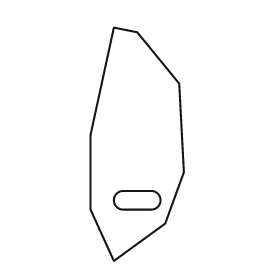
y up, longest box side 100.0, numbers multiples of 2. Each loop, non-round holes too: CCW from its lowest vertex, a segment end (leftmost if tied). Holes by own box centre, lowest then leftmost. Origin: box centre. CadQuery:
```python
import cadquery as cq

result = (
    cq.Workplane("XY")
    .moveTo(-10.0, -50.0)
    .lineTo(12.0, -34.0)
    .lineTo(20.0, -12.0)
    .lineTo(18.0, 26.0)
    .lineTo(0.0, 48.0)
    .lineTo(-10.0, 50.0)
    .lineTo(-20.0, 4.0)
    .lineTo(-20.0, -28.0)
    .close()
    .moveTo(-6.0, -28.0)
    .lineTo(6.0, -28.0)
    .threePointArc((10.0, -24.0), (6.0, -20.0))
    .lineTo(-6.0, -20.0)
    .threePointArc((-10.0, -24.0), (-6.0, -28.0))
    .close()
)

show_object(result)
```